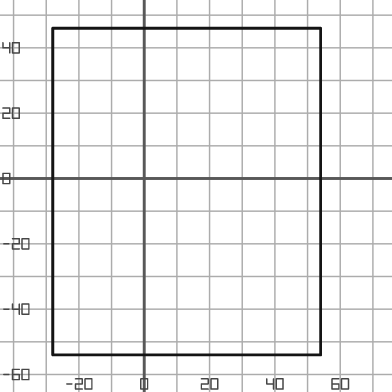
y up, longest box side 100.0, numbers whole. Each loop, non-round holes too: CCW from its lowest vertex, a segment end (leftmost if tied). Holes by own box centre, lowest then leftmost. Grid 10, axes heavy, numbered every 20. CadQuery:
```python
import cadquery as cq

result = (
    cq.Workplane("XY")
    .moveTo(-28.0, -54.0)
    .lineTo(54.0, -54.0)
    .lineTo(54.0, 46.0)
    .lineTo(-28.0, 46.0)
    .close()
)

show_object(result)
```